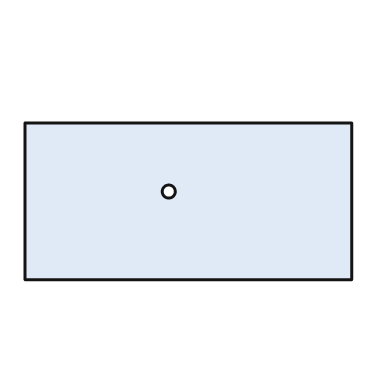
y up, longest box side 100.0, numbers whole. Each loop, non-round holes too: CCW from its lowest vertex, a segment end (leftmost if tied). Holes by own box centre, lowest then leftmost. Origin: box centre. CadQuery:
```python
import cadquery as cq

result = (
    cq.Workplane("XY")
    .moveTo(-50.0, -24.0)
    .lineTo(50.0, -24.0)
    .lineTo(50.0, 24.0)
    .lineTo(-50.0, 24.0)
    .close()
    .moveTo(-6.0, 3.0)
    .circle(2.0)
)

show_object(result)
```